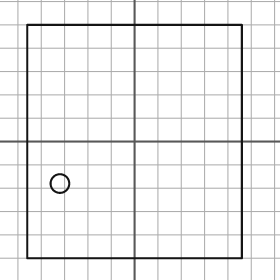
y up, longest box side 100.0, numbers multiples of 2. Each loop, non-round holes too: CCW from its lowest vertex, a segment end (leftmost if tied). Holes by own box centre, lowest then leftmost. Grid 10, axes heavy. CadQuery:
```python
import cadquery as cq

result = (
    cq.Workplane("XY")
    .moveTo(-46.0, -50.0)
    .lineTo(46.0, -50.0)
    .lineTo(46.0, 50.0)
    .lineTo(-46.0, 50.0)
    .close()
    .moveTo(-32.0, -18.0)
    .circle(4.0)
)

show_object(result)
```